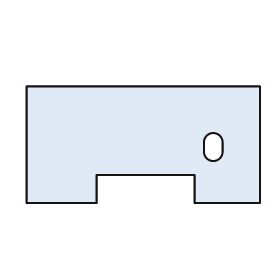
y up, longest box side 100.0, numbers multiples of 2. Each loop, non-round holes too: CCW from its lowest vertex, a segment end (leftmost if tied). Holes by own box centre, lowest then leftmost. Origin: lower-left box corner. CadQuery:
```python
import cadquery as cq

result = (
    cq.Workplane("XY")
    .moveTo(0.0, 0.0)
    .lineTo(30.0, 0.0)
    .lineTo(30.0, 12.0)
    .lineTo(72.0, 12.0)
    .lineTo(72.0, 0.0)
    .lineTo(100.0, 0.0)
    .lineTo(100.0, 50.0)
    .lineTo(0.0, 50.0)
    .close()
    .moveTo(76.0, 22.0)
    .threePointArc((80.0, 18.0), (84.0, 22.0))
    .lineTo(84.0, 26.0)
    .threePointArc((80.0, 30.0), (76.0, 26.0))
    .close()
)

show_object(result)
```